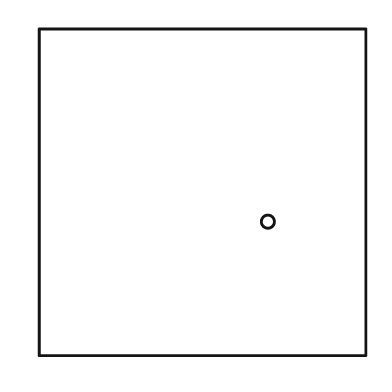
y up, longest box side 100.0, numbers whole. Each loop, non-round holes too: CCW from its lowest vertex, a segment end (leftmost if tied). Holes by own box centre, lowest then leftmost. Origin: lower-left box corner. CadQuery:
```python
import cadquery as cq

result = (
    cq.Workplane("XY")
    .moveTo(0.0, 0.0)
    .lineTo(100.0, 0.0)
    .lineTo(100.0, 100.0)
    .lineTo(0.0, 100.0)
    .close()
    .moveTo(70.0, 41.0)
    .circle(2.0)
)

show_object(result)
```